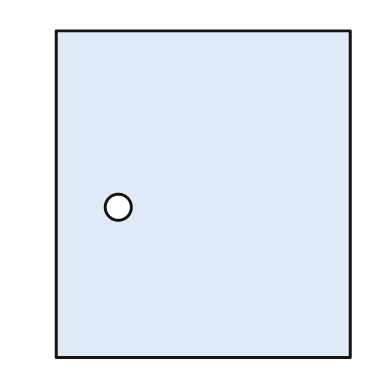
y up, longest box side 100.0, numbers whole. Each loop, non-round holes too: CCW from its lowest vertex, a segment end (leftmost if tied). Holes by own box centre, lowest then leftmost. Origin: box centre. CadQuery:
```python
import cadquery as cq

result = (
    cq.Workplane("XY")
    .moveTo(-45.0, -50.0)
    .lineTo(45.0, -50.0)
    .lineTo(45.0, 50.0)
    .lineTo(-45.0, 50.0)
    .close()
    .moveTo(-26.0, -4.0)
    .circle(4.0)
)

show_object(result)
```